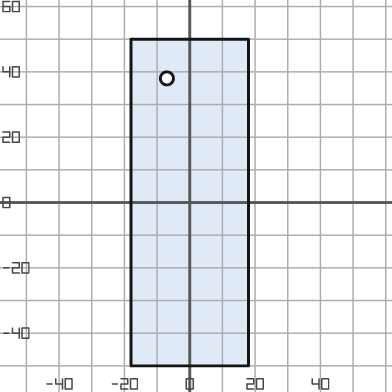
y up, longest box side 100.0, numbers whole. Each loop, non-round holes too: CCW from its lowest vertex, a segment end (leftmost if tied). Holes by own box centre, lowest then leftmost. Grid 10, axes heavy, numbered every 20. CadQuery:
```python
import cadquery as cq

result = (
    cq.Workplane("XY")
    .moveTo(-18.0, -50.0)
    .lineTo(18.0, -50.0)
    .lineTo(18.0, 50.0)
    .lineTo(-18.0, 50.0)
    .close()
    .moveTo(-7.0, 38.0)
    .circle(2.0)
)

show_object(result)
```